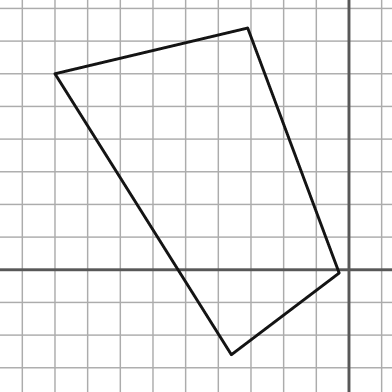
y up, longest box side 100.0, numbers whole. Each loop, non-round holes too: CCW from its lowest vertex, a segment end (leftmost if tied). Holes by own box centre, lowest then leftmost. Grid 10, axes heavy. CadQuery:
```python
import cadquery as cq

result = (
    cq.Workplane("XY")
    .moveTo(-36.0, -26.0)
    .lineTo(-3.0, -1.0)
    .lineTo(-31.0, 74.0)
    .lineTo(-90.0, 60.0)
    .close()
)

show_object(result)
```